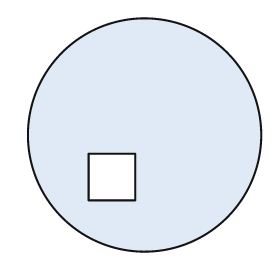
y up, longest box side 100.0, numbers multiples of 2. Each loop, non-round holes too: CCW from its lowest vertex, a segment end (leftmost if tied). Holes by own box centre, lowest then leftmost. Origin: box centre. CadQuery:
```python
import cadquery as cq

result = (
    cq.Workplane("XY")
    .moveTo(0.0, 0.0)
    .circle(50.0)
    .moveTo(-24.0, -28.0)
    .lineTo(-4.0, -28.0)
    .lineTo(-4.0, -8.0)
    .lineTo(-24.0, -8.0)
    .close()
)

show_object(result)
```